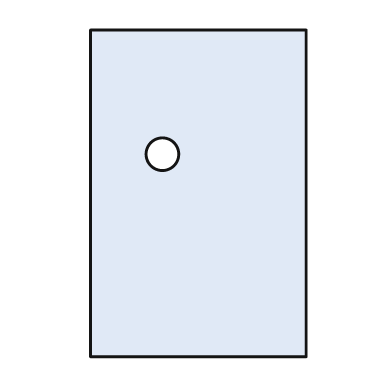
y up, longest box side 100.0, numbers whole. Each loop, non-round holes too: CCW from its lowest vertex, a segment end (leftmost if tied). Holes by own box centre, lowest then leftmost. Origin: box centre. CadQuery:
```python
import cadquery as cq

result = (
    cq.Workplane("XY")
    .moveTo(-33.0, -50.0)
    .lineTo(33.0, -50.0)
    .lineTo(33.0, 50.0)
    .lineTo(-33.0, 50.0)
    .close()
    .moveTo(-11.0, 12.0)
    .circle(5.0)
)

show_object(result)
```